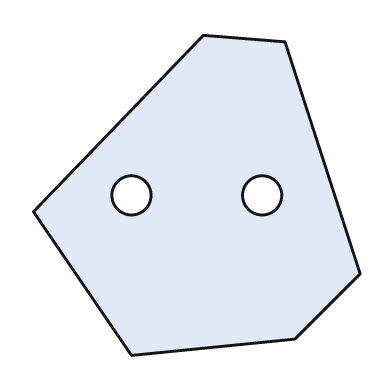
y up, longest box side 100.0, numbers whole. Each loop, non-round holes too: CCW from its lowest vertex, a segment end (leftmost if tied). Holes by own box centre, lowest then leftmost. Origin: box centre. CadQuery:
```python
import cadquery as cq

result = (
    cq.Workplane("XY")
    .moveTo(-20.0, -49.0)
    .lineTo(30.0, -44.0)
    .lineTo(50.0, -24.0)
    .lineTo(27.0, 47.0)
    .lineTo(2.0, 49.0)
    .lineTo(-50.0, -5.0)
    .close()
    .moveTo(-20.0, 0.0)
    .circle(6.0)
    .moveTo(20.0, 0.0)
    .circle(6.0)
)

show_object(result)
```